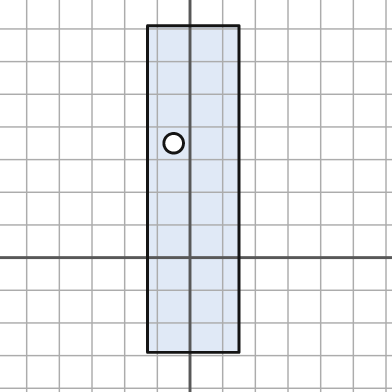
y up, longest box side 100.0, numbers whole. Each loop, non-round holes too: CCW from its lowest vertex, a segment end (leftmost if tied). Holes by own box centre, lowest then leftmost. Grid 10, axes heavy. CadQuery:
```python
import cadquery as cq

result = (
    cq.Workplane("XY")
    .moveTo(-13.0, -29.0)
    .lineTo(15.0, -29.0)
    .lineTo(15.0, 71.0)
    .lineTo(-13.0, 71.0)
    .close()
    .moveTo(-5.0, 35.0)
    .circle(3.0)
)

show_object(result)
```